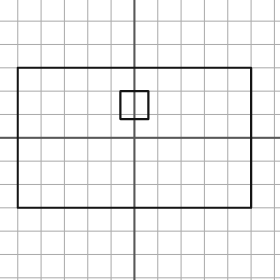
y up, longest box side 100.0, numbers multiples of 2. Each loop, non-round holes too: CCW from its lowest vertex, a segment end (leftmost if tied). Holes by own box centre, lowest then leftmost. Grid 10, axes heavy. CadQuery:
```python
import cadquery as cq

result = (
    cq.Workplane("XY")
    .moveTo(-50.0, -30.0)
    .lineTo(50.0, -30.0)
    .lineTo(50.0, 30.0)
    .lineTo(-50.0, 30.0)
    .close()
    .moveTo(-6.0, 8.0)
    .lineTo(6.0, 8.0)
    .lineTo(6.0, 20.0)
    .lineTo(-6.0, 20.0)
    .close()
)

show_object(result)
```